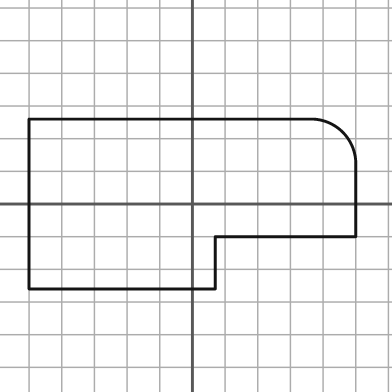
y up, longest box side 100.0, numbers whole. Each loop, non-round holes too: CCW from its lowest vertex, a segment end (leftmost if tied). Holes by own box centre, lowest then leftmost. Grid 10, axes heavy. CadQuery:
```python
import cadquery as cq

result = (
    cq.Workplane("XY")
    .moveTo(-50.0, -26.0)
    .lineTo(7.0, -26.0)
    .lineTo(7.0, -10.0)
    .lineTo(50.0, -10.0)
    .lineTo(50.0, 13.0)
    .threePointArc((46.0, 22.0), (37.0, 26.0))
    .lineTo(-50.0, 26.0)
    .close()
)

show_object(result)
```